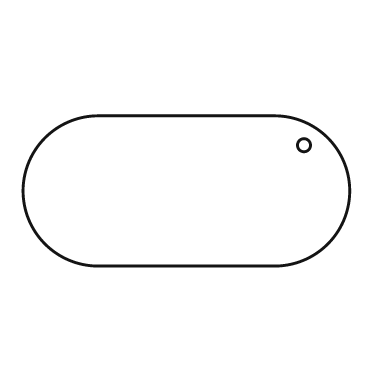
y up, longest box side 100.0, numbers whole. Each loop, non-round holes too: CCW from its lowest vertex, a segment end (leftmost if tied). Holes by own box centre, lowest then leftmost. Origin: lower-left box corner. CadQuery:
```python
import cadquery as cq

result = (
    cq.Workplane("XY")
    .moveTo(23.0, 0.0)
    .lineTo(77.0, 0.0)
    .threePointArc((100.0, 23.0), (77.0, 46.0))
    .lineTo(23.0, 46.0)
    .threePointArc((0.0, 23.0), (23.0, 0.0))
    .close()
    .moveTo(86.0, 37.0)
    .circle(2.0)
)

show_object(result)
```